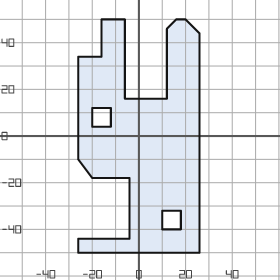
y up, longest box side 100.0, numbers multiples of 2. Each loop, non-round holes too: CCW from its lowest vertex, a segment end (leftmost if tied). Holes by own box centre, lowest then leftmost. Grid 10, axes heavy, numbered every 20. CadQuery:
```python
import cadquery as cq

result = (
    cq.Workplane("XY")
    .moveTo(-26.0, -50.0)
    .lineTo(26.0, -50.0)
    .lineTo(26.0, 44.0)
    .lineTo(20.0, 50.0)
    .lineTo(16.0, 50.0)
    .lineTo(12.0, 46.0)
    .lineTo(12.0, 16.0)
    .lineTo(-6.0, 16.0)
    .lineTo(-6.0, 50.0)
    .lineTo(-16.0, 50.0)
    .lineTo(-16.0, 34.0)
    .lineTo(-26.0, 34.0)
    .lineTo(-26.0, -10.0)
    .lineTo(-20.0, -18.0)
    .lineTo(-4.0, -18.0)
    .lineTo(-4.0, -44.0)
    .lineTo(-26.0, -44.0)
    .close()
    .moveTo(10.0, -40.0)
    .lineTo(18.0, -40.0)
    .lineTo(18.0, -32.0)
    .lineTo(10.0, -32.0)
    .close()
    .moveTo(-20.0, 4.0)
    .lineTo(-12.0, 4.0)
    .lineTo(-12.0, 12.0)
    .lineTo(-20.0, 12.0)
    .close()
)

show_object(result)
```